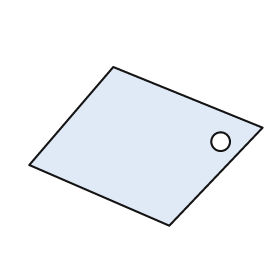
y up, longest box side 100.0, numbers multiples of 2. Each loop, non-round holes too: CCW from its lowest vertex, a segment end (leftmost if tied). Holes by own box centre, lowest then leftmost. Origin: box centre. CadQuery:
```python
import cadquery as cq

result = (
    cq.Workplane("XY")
    .moveTo(10.0, -34.0)
    .lineTo(50.0, 8.0)
    .lineTo(-14.0, 34.0)
    .lineTo(-50.0, -8.0)
    .close()
    .moveTo(32.0, 2.0)
    .circle(4.0)
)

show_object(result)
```